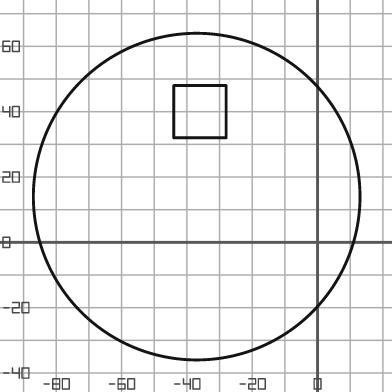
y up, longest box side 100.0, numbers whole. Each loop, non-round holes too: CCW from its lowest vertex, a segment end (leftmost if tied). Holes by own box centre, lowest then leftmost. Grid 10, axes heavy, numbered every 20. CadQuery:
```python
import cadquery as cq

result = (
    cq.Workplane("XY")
    .moveTo(-37.0, 14.0)
    .circle(50.0)
    .moveTo(-44.0, 32.0)
    .lineTo(-28.0, 32.0)
    .lineTo(-28.0, 48.0)
    .lineTo(-44.0, 48.0)
    .close()
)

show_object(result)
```